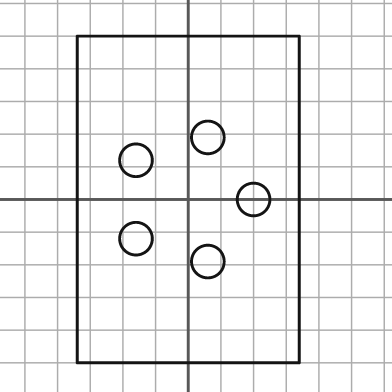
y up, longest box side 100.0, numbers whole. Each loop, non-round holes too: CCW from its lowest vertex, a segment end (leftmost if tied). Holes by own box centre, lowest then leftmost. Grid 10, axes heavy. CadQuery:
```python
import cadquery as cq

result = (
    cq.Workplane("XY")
    .moveTo(-34.0, -50.0)
    .lineTo(34.0, -50.0)
    .lineTo(34.0, 50.0)
    .lineTo(-34.0, 50.0)
    .close()
    .moveTo(6.0, -19.0)
    .circle(5.0)
    .moveTo(-16.0, -12.0)
    .circle(5.0)
    .moveTo(20.0, 0.0)
    .circle(5.0)
    .moveTo(-16.0, 12.0)
    .circle(5.0)
    .moveTo(6.0, 19.0)
    .circle(5.0)
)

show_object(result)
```